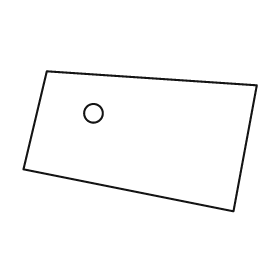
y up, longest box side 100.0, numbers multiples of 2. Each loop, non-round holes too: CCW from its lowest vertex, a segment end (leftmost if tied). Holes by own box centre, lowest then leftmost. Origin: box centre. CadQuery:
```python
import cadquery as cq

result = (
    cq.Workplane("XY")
    .moveTo(40.0, -30.0)
    .lineTo(50.0, 24.0)
    .lineTo(-40.0, 30.0)
    .lineTo(-50.0, -12.0)
    .close()
    .moveTo(-20.0, 12.0)
    .circle(4.0)
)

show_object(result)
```